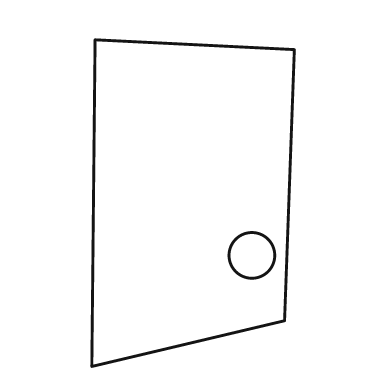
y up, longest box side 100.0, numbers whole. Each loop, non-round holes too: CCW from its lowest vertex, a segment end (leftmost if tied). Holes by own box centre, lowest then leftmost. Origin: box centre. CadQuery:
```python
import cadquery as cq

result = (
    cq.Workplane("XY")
    .moveTo(-31.0, -50.0)
    .lineTo(28.0, -36.0)
    .lineTo(31.0, 47.0)
    .lineTo(-30.0, 50.0)
    .close()
    .moveTo(18.0, -16.0)
    .circle(7.0)
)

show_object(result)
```